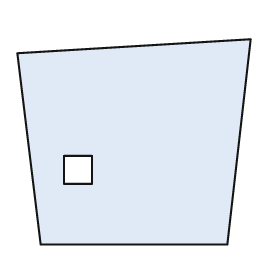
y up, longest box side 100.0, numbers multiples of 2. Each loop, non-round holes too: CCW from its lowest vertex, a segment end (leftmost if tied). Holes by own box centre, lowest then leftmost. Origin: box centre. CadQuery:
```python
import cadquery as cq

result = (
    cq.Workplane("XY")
    .moveTo(-40.0, -44.0)
    .lineTo(40.0, -44.0)
    .lineTo(50.0, 44.0)
    .lineTo(-50.0, 38.0)
    .close()
    .moveTo(-30.0, -18.0)
    .lineTo(-18.0, -18.0)
    .lineTo(-18.0, -6.0)
    .lineTo(-30.0, -6.0)
    .close()
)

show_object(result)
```